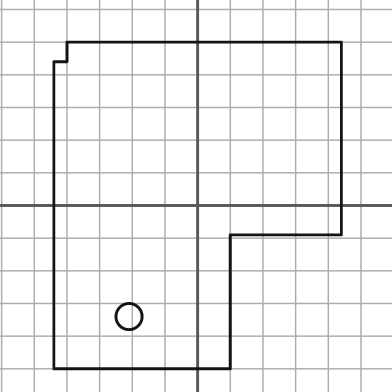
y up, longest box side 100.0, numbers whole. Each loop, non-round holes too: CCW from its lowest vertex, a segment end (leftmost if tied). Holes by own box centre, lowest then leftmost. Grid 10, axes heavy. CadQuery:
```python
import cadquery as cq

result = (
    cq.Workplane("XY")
    .moveTo(-44.0, -50.0)
    .lineTo(10.0, -50.0)
    .lineTo(10.0, -9.0)
    .lineTo(44.0, -9.0)
    .lineTo(44.0, 50.0)
    .lineTo(-40.0, 50.0)
    .lineTo(-40.0, 44.0)
    .lineTo(-44.0, 44.0)
    .close()
    .moveTo(-21.0, -34.0)
    .circle(4.0)
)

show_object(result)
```